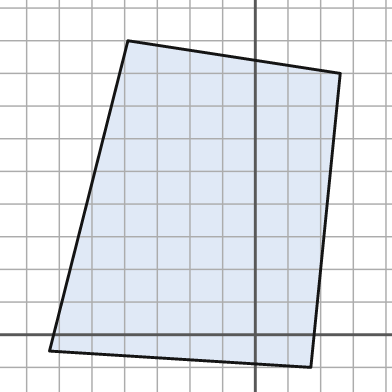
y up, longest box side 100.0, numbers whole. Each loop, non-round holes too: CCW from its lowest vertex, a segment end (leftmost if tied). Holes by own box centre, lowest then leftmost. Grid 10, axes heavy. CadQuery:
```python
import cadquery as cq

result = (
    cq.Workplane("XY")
    .moveTo(17.0, -10.0)
    .lineTo(26.0, 80.0)
    .lineTo(-39.0, 90.0)
    .lineTo(-63.0, -5.0)
    .close()
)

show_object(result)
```